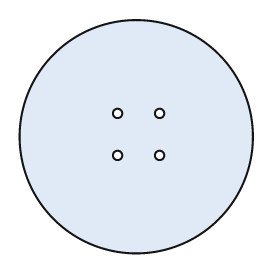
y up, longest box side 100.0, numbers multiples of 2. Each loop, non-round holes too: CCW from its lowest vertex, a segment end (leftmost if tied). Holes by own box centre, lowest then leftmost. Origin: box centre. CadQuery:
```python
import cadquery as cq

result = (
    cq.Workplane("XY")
    .moveTo(0.0, 0.0)
    .circle(50.0)
    .moveTo(-8.0, -8.0)
    .circle(2.0)
    .moveTo(10.0, -8.0)
    .circle(2.0)
    .moveTo(-8.0, 10.0)
    .circle(2.0)
    .moveTo(10.0, 10.0)
    .circle(2.0)
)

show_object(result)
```